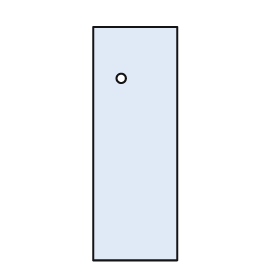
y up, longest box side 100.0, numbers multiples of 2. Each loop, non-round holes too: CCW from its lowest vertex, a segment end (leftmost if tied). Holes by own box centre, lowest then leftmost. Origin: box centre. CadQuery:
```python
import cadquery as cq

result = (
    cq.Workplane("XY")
    .moveTo(-18.0, -50.0)
    .lineTo(18.0, -50.0)
    .lineTo(18.0, 50.0)
    .lineTo(-18.0, 50.0)
    .close()
    .moveTo(-6.0, 28.0)
    .circle(2.0)
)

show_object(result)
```